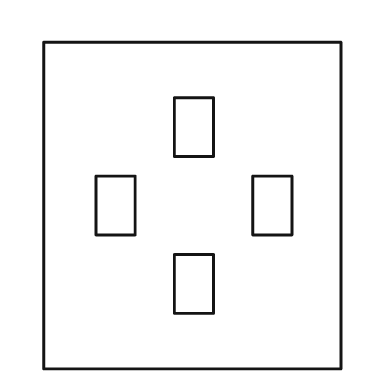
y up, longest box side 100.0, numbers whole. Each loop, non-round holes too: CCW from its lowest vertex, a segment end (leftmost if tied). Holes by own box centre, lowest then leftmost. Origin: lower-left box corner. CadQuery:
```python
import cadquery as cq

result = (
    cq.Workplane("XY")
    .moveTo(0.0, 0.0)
    .lineTo(91.0, 0.0)
    .lineTo(91.0, 100.0)
    .lineTo(0.0, 100.0)
    .close()
    .moveTo(40.0, 17.0)
    .lineTo(52.0, 17.0)
    .lineTo(52.0, 35.0)
    .lineTo(40.0, 35.0)
    .close()
    .moveTo(16.0, 41.0)
    .lineTo(28.0, 41.0)
    .lineTo(28.0, 59.0)
    .lineTo(16.0, 59.0)
    .close()
    .moveTo(64.0, 41.0)
    .lineTo(76.0, 41.0)
    .lineTo(76.0, 59.0)
    .lineTo(64.0, 59.0)
    .close()
    .moveTo(40.0, 65.0)
    .lineTo(52.0, 65.0)
    .lineTo(52.0, 83.0)
    .lineTo(40.0, 83.0)
    .close()
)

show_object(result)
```